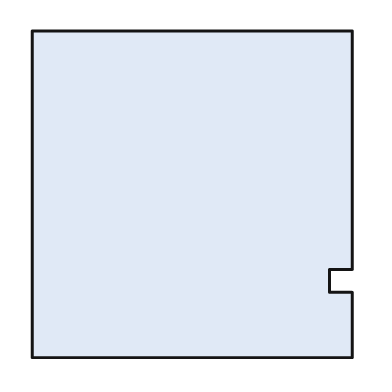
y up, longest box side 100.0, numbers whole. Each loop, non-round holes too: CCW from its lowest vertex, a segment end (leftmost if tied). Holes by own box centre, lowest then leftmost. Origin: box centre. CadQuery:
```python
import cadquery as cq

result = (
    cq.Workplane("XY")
    .moveTo(-49.0, -50.0)
    .lineTo(49.0, -50.0)
    .lineTo(49.0, -30.0)
    .lineTo(42.0, -30.0)
    .lineTo(42.0, -23.0)
    .lineTo(49.0, -23.0)
    .lineTo(49.0, 50.0)
    .lineTo(-49.0, 50.0)
    .close()
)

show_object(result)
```